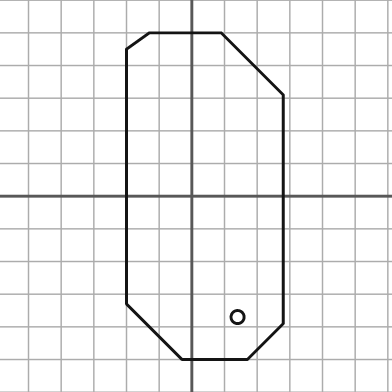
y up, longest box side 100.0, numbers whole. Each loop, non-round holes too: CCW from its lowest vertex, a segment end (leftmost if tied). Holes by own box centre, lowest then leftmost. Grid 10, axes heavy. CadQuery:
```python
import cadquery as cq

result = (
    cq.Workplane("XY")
    .moveTo(-3.0, -50.0)
    .lineTo(17.0, -50.0)
    .lineTo(28.0, -39.0)
    .lineTo(28.0, 31.0)
    .lineTo(9.0, 50.0)
    .lineTo(-13.0, 50.0)
    .lineTo(-20.0, 45.0)
    .lineTo(-20.0, -33.0)
    .close()
    .moveTo(14.0, -37.0)
    .circle(2.0)
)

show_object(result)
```